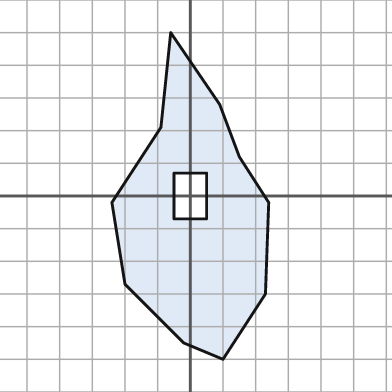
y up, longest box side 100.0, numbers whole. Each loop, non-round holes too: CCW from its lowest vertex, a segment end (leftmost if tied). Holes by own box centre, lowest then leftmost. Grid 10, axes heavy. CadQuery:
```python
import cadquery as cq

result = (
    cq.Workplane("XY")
    .moveTo(10.0, -50.0)
    .lineTo(23.0, -30.0)
    .lineTo(24.0, -2.0)
    .lineTo(15.0, 12.0)
    .lineTo(9.0, 28.0)
    .lineTo(-6.0, 50.0)
    .lineTo(-9.0, 21.0)
    .lineTo(-24.0, -2.0)
    .lineTo(-20.0, -27.0)
    .lineTo(-2.0, -45.0)
    .close()
    .moveTo(-5.0, -7.0)
    .lineTo(5.0, -7.0)
    .lineTo(5.0, 7.0)
    .lineTo(-5.0, 7.0)
    .close()
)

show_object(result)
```